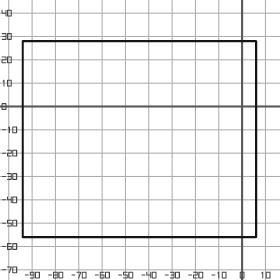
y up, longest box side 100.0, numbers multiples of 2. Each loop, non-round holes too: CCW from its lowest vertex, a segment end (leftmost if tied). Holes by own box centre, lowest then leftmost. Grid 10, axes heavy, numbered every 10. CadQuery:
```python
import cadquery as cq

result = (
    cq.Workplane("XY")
    .moveTo(-94.0, -56.0)
    .lineTo(6.0, -56.0)
    .lineTo(6.0, 28.0)
    .lineTo(-94.0, 28.0)
    .close()
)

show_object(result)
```